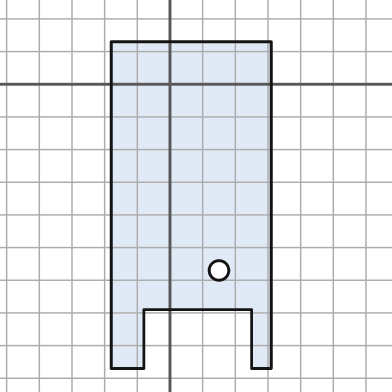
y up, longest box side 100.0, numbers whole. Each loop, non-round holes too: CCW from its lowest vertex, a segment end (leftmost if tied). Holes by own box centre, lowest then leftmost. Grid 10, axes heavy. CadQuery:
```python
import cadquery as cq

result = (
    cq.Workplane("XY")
    .moveTo(-18.0, -87.0)
    .lineTo(-8.0, -87.0)
    .lineTo(-8.0, -69.0)
    .lineTo(25.0, -69.0)
    .lineTo(25.0, -87.0)
    .lineTo(31.0, -87.0)
    .lineTo(31.0, 13.0)
    .lineTo(-18.0, 13.0)
    .close()
    .moveTo(15.0, -57.0)
    .circle(3.0)
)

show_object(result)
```